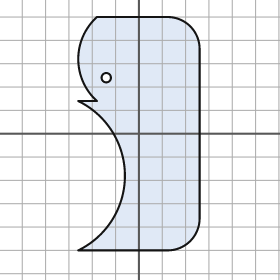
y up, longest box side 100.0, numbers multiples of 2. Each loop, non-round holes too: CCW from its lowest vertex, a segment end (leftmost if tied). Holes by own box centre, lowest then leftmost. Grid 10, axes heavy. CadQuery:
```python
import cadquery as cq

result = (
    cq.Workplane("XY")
    .moveTo(-26.0, -50.0)
    .lineTo(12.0, -50.0)
    .threePointArc((22.0, -46.0), (26.0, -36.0))
    .lineTo(26.0, 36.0)
    .threePointArc((22.0, 46.0), (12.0, 50.0))
    .lineTo(-18.0, 50.0)
    .threePointArc((-26.0, 32.0), (-18.0, 14.0))
    .lineTo(-26.0, 14.0)
    .threePointArc((-6.0, -18.0), (-26.0, -50.0))
    .close()
    .moveTo(-14.0, 24.0)
    .circle(2.0)
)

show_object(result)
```